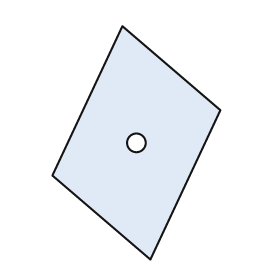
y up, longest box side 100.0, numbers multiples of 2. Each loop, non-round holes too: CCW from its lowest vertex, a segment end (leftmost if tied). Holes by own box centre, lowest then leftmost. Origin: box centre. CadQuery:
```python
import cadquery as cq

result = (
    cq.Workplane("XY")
    .moveTo(6.0, -50.0)
    .lineTo(36.0, 14.0)
    .lineTo(-6.0, 50.0)
    .lineTo(-36.0, -14.0)
    .close()
    .moveTo(0.0, 0.0)
    .circle(4.0)
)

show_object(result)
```